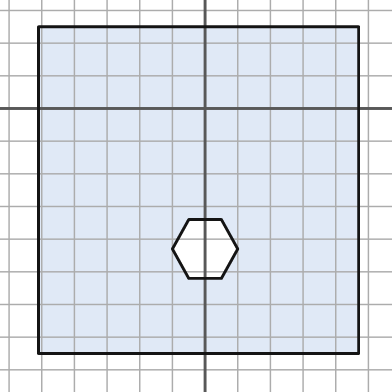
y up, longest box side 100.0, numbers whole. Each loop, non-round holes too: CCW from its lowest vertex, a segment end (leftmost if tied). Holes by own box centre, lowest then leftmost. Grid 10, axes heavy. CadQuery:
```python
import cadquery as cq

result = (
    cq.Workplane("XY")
    .moveTo(-51.0, -75.0)
    .lineTo(47.0, -75.0)
    .lineTo(47.0, 25.0)
    .lineTo(-51.0, 25.0)
    .close()
    .moveTo(-5.0, -52.0)
    .lineTo(5.0, -52.0)
    .lineTo(10.0, -43.0)
    .lineTo(5.0, -34.0)
    .lineTo(-5.0, -34.0)
    .lineTo(-10.0, -43.0)
    .close()
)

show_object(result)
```